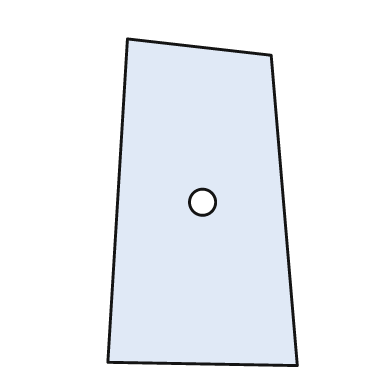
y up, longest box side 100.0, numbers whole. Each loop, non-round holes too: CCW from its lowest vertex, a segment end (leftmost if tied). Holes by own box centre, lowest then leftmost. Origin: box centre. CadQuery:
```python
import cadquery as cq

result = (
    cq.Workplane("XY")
    .moveTo(29.0, -50.0)
    .lineTo(21.0, 45.0)
    .lineTo(-23.0, 50.0)
    .lineTo(-29.0, -49.0)
    .close()
    .moveTo(0.0, 0.0)
    .circle(4.0)
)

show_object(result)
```